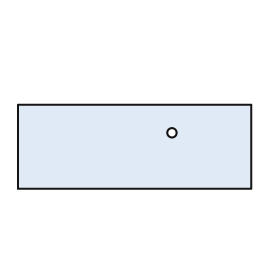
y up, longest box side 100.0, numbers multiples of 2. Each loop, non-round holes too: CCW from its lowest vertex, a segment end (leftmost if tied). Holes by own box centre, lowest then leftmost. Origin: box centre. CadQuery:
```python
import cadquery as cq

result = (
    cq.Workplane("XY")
    .moveTo(-50.0, -18.0)
    .lineTo(50.0, -18.0)
    .lineTo(50.0, 18.0)
    .lineTo(-50.0, 18.0)
    .close()
    .moveTo(16.0, 6.0)
    .circle(2.0)
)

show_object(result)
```